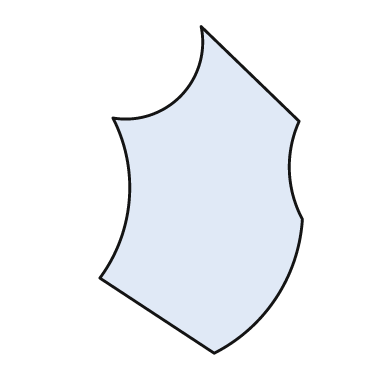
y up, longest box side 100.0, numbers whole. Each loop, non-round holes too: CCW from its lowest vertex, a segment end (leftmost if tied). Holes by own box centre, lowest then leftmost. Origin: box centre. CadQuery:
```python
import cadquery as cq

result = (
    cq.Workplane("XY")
    .moveTo(4.0, -50.0)
    .threePointArc((23.0, -33.0), (31.0, -9.0))
    .threePointArc((27.0, 6.0), (30.0, 21.0))
    .lineTo(0.0, 50.0)
    .threePointArc((-6.0, 29.0), (-27.0, 22.0))
    .threePointArc((-22.0, -3.0), (-31.0, -27.0))
    .close()
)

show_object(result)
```